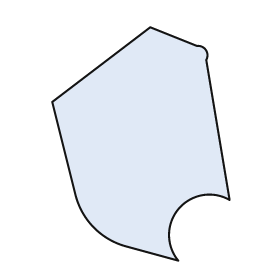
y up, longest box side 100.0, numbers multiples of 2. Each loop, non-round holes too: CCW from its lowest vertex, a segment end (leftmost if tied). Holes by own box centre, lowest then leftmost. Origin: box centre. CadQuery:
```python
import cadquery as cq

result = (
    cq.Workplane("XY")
    .moveTo(16.0, -50.0)
    .threePointArc((16.0, -28.0), (38.0, -24.0))
    .lineTo(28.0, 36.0)
    .threePointArc((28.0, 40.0), (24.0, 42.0))
    .lineTo(4.0, 50.0)
    .lineTo(-38.0, 18.0)
    .lineTo(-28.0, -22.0)
    .threePointArc((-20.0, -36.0), (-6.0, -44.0))
    .close()
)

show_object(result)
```